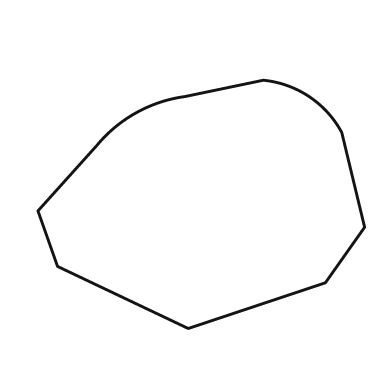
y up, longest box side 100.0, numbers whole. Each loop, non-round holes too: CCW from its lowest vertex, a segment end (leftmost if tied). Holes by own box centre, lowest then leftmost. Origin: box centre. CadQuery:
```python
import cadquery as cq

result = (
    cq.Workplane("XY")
    .moveTo(-4.0, -38.0)
    .lineTo(38.0, -24.0)
    .lineTo(50.0, -7.0)
    .lineTo(43.0, 22.0)
    .threePointArc((33.0, 33.0), (19.0, 38.0))
    .lineTo(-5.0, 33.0)
    .threePointArc((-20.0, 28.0), (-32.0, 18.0))
    .lineTo(-50.0, -2.0)
    .lineTo(-44.0, -19.0)
    .close()
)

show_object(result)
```